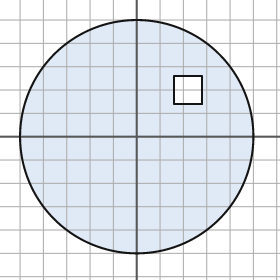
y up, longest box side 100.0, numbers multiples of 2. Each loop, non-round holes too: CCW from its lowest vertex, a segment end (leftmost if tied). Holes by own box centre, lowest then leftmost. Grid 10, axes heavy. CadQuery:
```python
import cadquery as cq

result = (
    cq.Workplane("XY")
    .moveTo(0.0, 0.0)
    .circle(50.0)
    .moveTo(16.0, 14.0)
    .lineTo(28.0, 14.0)
    .lineTo(28.0, 26.0)
    .lineTo(16.0, 26.0)
    .close()
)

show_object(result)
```